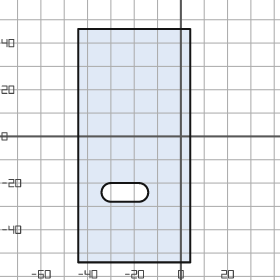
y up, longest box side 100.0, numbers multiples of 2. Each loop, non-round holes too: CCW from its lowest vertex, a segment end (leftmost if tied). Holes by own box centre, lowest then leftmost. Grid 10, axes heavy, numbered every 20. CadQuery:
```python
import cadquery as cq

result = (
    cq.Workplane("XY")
    .moveTo(-44.0, -54.0)
    .lineTo(4.0, -54.0)
    .lineTo(4.0, 46.0)
    .lineTo(-44.0, 46.0)
    .close()
    .moveTo(-30.0, -28.0)
    .lineTo(-18.0, -28.0)
    .threePointArc((-14.0, -24.0), (-18.0, -20.0))
    .lineTo(-30.0, -20.0)
    .threePointArc((-34.0, -24.0), (-30.0, -28.0))
    .close()
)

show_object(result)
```